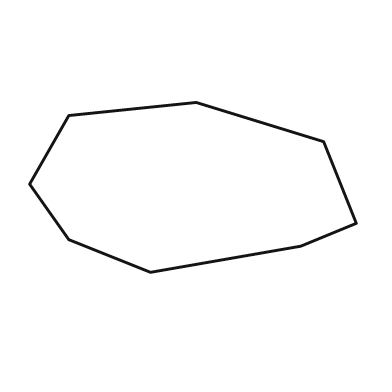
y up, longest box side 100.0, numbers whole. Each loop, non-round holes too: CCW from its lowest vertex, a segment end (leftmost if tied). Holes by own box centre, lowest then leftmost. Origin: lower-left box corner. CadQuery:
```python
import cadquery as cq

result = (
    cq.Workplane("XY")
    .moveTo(37.0, 0.0)
    .lineTo(83.0, 8.0)
    .lineTo(100.0, 15.0)
    .lineTo(90.0, 40.0)
    .lineTo(51.0, 52.0)
    .lineTo(12.0, 48.0)
    .lineTo(0.0, 27.0)
    .lineTo(12.0, 10.0)
    .close()
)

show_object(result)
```